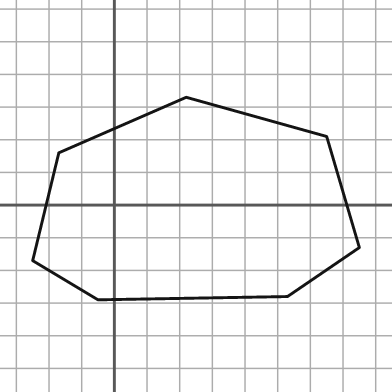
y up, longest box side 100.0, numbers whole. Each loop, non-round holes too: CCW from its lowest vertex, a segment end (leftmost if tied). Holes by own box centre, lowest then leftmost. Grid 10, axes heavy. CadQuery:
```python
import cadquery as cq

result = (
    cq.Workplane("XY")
    .moveTo(-5.0, -29.0)
    .lineTo(53.0, -28.0)
    .lineTo(75.0, -13.0)
    .lineTo(65.0, 21.0)
    .lineTo(22.0, 33.0)
    .lineTo(-17.0, 16.0)
    .lineTo(-25.0, -17.0)
    .close()
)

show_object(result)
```